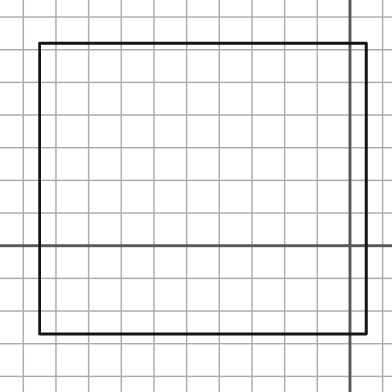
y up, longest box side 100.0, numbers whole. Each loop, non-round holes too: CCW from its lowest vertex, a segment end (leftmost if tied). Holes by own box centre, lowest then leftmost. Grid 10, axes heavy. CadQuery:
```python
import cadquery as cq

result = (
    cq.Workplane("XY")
    .moveTo(-95.0, -27.0)
    .lineTo(5.0, -27.0)
    .lineTo(5.0, 62.0)
    .lineTo(-95.0, 62.0)
    .close()
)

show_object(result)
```